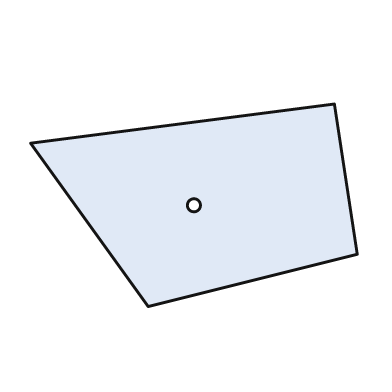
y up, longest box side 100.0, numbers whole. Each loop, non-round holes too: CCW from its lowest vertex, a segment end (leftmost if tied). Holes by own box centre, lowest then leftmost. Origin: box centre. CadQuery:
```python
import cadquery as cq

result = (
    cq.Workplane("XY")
    .moveTo(-14.0, -31.0)
    .lineTo(50.0, -15.0)
    .lineTo(43.0, 31.0)
    .lineTo(-50.0, 19.0)
    .close()
    .moveTo(0.0, 0.0)
    .circle(2.0)
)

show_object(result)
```